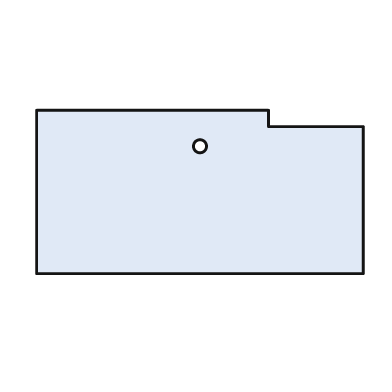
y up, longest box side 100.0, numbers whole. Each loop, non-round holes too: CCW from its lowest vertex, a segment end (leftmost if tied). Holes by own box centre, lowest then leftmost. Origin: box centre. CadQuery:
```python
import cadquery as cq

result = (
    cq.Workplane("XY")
    .moveTo(-50.0, -25.0)
    .lineTo(50.0, -25.0)
    .lineTo(50.0, 20.0)
    .lineTo(21.0, 20.0)
    .lineTo(21.0, 25.0)
    .lineTo(-50.0, 25.0)
    .close()
    .moveTo(0.0, 14.0)
    .circle(2.0)
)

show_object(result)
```